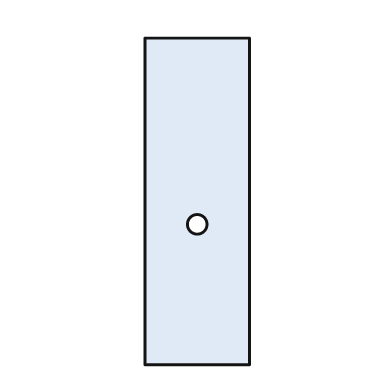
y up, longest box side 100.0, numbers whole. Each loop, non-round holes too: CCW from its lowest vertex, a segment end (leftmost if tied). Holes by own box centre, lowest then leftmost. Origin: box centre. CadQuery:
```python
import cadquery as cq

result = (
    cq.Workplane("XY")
    .moveTo(-16.0, -50.0)
    .lineTo(16.0, -50.0)
    .lineTo(16.0, 50.0)
    .lineTo(-16.0, 50.0)
    .close()
    .moveTo(0.0, -7.0)
    .circle(3.0)
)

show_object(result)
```